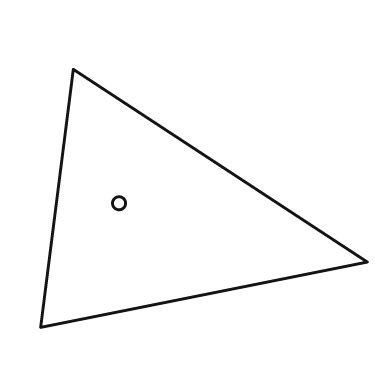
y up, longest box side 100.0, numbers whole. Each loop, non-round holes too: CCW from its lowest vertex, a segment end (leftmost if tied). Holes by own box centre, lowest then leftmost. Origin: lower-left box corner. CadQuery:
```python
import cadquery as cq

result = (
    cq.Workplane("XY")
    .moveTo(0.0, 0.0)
    .lineTo(100.0, 20.0)
    .lineTo(10.0, 79.0)
    .close()
    .moveTo(24.0, 38.0)
    .circle(2.0)
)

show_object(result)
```